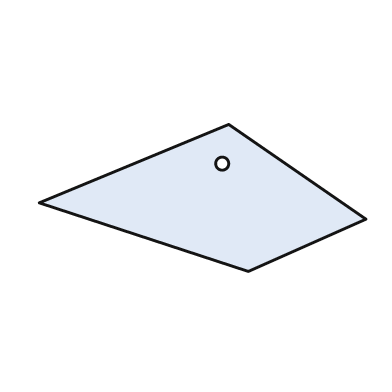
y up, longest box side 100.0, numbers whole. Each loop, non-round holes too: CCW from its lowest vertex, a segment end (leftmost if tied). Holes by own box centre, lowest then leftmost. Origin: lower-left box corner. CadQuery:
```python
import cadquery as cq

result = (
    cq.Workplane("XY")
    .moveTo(64.0, 0.0)
    .lineTo(100.0, 16.0)
    .lineTo(58.0, 45.0)
    .lineTo(0.0, 21.0)
    .close()
    .moveTo(56.0, 33.0)
    .circle(2.0)
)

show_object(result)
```